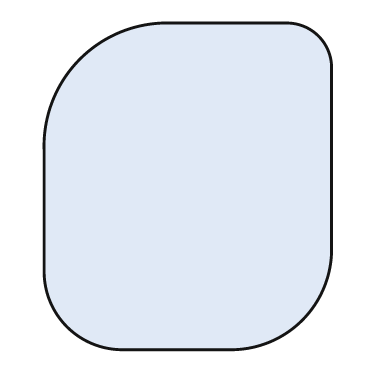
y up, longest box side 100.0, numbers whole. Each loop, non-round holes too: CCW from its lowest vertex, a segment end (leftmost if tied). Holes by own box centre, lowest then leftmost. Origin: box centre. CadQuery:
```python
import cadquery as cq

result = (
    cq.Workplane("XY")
    .moveTo(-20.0, -50.0)
    .lineTo(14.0, -50.0)
    .threePointArc((35.0, -41.0), (44.0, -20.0))
    .lineTo(44.0, 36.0)
    .threePointArc((40.0, 46.0), (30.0, 50.0))
    .lineTo(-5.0, 50.0)
    .threePointArc((-33.0, 39.0), (-44.0, 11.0))
    .lineTo(-44.0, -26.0)
    .threePointArc((-37.0, -43.0), (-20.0, -50.0))
    .close()
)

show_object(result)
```